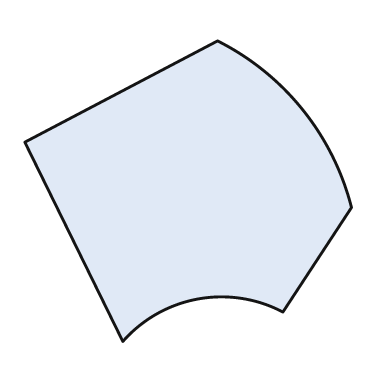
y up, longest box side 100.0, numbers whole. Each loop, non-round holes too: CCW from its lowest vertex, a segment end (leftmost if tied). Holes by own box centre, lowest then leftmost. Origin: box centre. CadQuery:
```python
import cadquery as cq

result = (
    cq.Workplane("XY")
    .moveTo(-20.0, -46.0)
    .threePointArc((3.0, -33.0), (29.0, -37.0))
    .lineTo(50.0, -5.0)
    .threePointArc((35.0, 25.0), (9.0, 46.0))
    .lineTo(-50.0, 15.0)
    .close()
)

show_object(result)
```